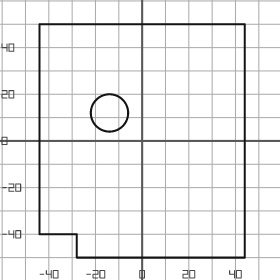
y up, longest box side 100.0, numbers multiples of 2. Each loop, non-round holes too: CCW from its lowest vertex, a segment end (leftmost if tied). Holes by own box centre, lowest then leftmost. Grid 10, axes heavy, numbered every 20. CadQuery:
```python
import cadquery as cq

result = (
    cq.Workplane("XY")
    .moveTo(-28.0, -50.0)
    .lineTo(44.0, -50.0)
    .lineTo(44.0, 50.0)
    .lineTo(-44.0, 50.0)
    .lineTo(-44.0, -40.0)
    .lineTo(-28.0, -40.0)
    .close()
    .moveTo(-14.0, 12.0)
    .circle(8.0)
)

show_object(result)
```